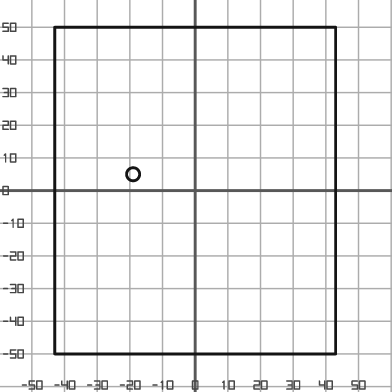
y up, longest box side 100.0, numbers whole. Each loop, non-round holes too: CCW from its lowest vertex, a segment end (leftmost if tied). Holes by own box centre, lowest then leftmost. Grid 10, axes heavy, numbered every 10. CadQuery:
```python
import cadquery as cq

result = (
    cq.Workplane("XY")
    .moveTo(-43.0, -50.0)
    .lineTo(43.0, -50.0)
    .lineTo(43.0, 50.0)
    .lineTo(-43.0, 50.0)
    .close()
    .moveTo(-19.0, 5.0)
    .circle(2.0)
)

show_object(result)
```